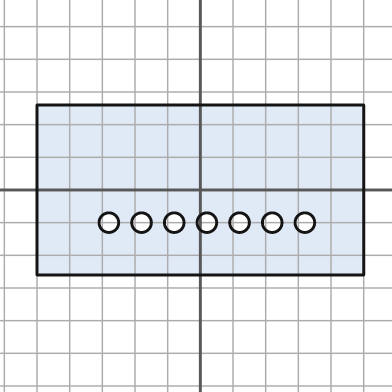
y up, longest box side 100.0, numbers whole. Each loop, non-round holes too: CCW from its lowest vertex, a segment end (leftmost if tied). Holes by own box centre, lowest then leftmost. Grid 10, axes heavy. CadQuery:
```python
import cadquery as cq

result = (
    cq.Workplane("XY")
    .moveTo(-50.0, -26.0)
    .lineTo(50.0, -26.0)
    .lineTo(50.0, 26.0)
    .lineTo(-50.0, 26.0)
    .close()
    .moveTo(-28.0, -10.0)
    .circle(3.0)
    .moveTo(-18.0, -10.0)
    .circle(3.0)
    .moveTo(-8.0, -10.0)
    .circle(3.0)
    .moveTo(2.0, -10.0)
    .circle(3.0)
    .moveTo(12.0, -10.0)
    .circle(3.0)
    .moveTo(22.0, -10.0)
    .circle(3.0)
    .moveTo(32.0, -10.0)
    .circle(3.0)
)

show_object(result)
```